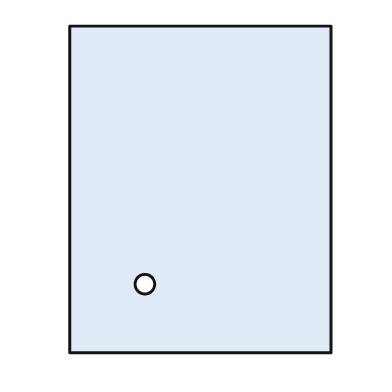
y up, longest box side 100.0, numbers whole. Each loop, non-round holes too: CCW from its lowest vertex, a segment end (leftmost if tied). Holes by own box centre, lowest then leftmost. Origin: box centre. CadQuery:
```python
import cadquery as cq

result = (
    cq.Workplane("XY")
    .moveTo(-40.0, -50.0)
    .lineTo(40.0, -50.0)
    .lineTo(40.0, 50.0)
    .lineTo(-40.0, 50.0)
    .close()
    .moveTo(-17.0, -29.0)
    .circle(3.0)
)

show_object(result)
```